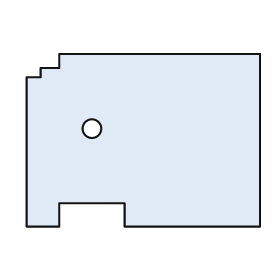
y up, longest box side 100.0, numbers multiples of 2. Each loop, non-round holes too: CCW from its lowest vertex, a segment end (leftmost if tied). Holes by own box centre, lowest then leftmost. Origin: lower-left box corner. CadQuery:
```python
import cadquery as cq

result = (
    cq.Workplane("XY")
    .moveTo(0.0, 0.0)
    .lineTo(14.0, 0.0)
    .lineTo(14.0, 10.0)
    .lineTo(42.0, 10.0)
    .lineTo(42.0, 0.0)
    .lineTo(100.0, 0.0)
    .lineTo(100.0, 74.0)
    .lineTo(14.0, 74.0)
    .lineTo(14.0, 68.0)
    .lineTo(6.0, 68.0)
    .lineTo(6.0, 64.0)
    .lineTo(0.0, 64.0)
    .close()
    .moveTo(28.0, 42.0)
    .circle(4.0)
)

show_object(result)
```